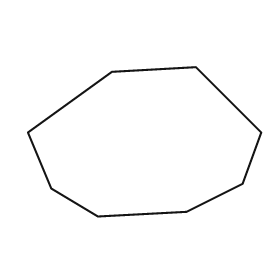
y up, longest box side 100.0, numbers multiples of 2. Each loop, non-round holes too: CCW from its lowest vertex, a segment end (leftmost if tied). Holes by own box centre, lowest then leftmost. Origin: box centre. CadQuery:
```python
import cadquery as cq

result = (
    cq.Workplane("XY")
    .moveTo(-20.0, -32.0)
    .lineTo(18.0, -30.0)
    .lineTo(42.0, -18.0)
    .lineTo(50.0, 4.0)
    .lineTo(22.0, 32.0)
    .lineTo(-14.0, 30.0)
    .lineTo(-50.0, 4.0)
    .lineTo(-40.0, -20.0)
    .close()
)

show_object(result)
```